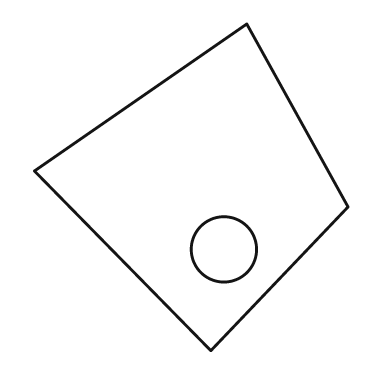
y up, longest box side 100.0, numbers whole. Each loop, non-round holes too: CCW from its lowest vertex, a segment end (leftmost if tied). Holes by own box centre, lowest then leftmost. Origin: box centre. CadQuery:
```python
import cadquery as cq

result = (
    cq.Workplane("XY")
    .moveTo(6.0, -50.0)
    .lineTo(48.0, -6.0)
    .lineTo(17.0, 50.0)
    .lineTo(-48.0, 5.0)
    .close()
    .moveTo(10.0, -19.0)
    .circle(10.0)
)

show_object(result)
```